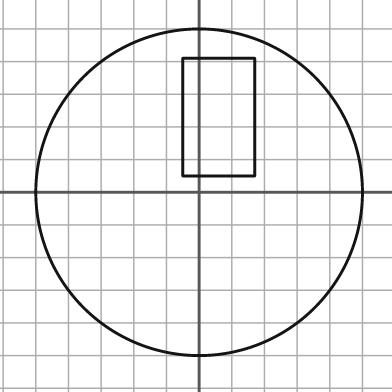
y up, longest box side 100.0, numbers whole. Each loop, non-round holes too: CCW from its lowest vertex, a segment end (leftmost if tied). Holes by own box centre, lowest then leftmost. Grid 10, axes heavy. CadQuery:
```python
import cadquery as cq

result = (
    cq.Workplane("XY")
    .moveTo(0.0, 0.0)
    .circle(50.0)
    .moveTo(-5.0, 5.0)
    .lineTo(17.0, 5.0)
    .lineTo(17.0, 41.0)
    .lineTo(-5.0, 41.0)
    .close()
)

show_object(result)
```